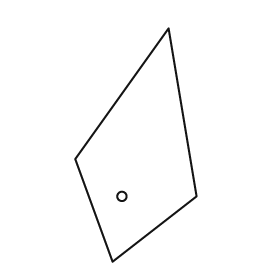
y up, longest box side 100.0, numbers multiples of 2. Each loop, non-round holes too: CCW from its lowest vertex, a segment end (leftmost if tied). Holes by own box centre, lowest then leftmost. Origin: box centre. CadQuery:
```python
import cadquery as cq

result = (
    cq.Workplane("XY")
    .moveTo(-10.0, -50.0)
    .lineTo(26.0, -22.0)
    .lineTo(14.0, 50.0)
    .lineTo(-26.0, -6.0)
    .close()
    .moveTo(-6.0, -22.0)
    .circle(2.0)
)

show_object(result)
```